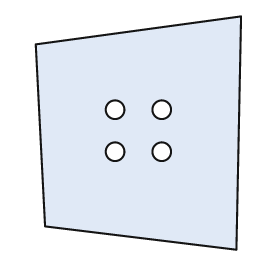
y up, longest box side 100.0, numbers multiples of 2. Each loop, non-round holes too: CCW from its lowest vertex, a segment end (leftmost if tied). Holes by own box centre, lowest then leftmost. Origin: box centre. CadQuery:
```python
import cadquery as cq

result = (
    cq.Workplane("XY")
    .moveTo(42.0, -50.0)
    .lineTo(44.0, 50.0)
    .lineTo(-44.0, 38.0)
    .lineTo(-40.0, -40.0)
    .close()
    .moveTo(-10.0, -8.0)
    .circle(4.0)
    .moveTo(10.0, -8.0)
    .circle(4.0)
    .moveTo(-10.0, 10.0)
    .circle(4.0)
    .moveTo(10.0, 10.0)
    .circle(4.0)
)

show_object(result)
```